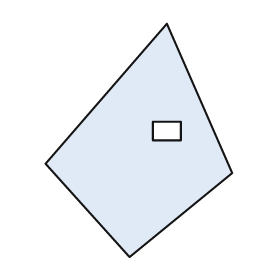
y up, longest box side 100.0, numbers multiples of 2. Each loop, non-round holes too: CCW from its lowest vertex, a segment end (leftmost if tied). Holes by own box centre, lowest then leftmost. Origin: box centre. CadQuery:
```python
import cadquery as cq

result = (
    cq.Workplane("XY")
    .moveTo(-4.0, -50.0)
    .lineTo(40.0, -14.0)
    .lineTo(12.0, 50.0)
    .lineTo(-40.0, -10.0)
    .close()
    .moveTo(6.0, 0.0)
    .lineTo(18.0, 0.0)
    .lineTo(18.0, 8.0)
    .lineTo(6.0, 8.0)
    .close()
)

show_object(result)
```